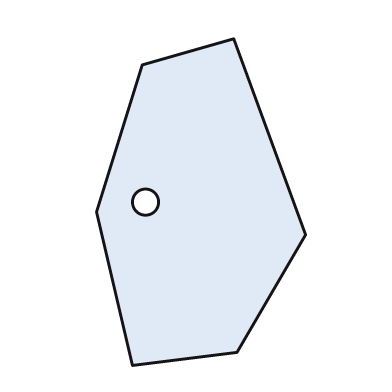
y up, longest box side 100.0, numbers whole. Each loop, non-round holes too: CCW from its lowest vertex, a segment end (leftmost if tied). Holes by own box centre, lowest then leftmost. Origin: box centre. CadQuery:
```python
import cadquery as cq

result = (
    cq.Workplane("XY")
    .moveTo(-21.0, -50.0)
    .lineTo(11.0, -46.0)
    .lineTo(32.0, -10.0)
    .lineTo(10.0, 50.0)
    .lineTo(-18.0, 42.0)
    .lineTo(-32.0, -3.0)
    .close()
    .moveTo(-17.0, 0.0)
    .circle(4.0)
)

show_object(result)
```